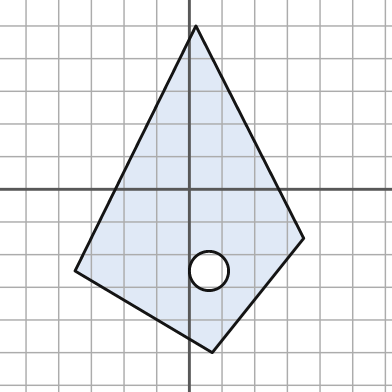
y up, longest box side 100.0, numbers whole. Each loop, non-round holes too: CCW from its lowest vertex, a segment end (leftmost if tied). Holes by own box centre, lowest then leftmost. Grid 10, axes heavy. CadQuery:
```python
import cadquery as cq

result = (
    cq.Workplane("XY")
    .moveTo(7.0, -50.0)
    .lineTo(35.0, -15.0)
    .lineTo(2.0, 50.0)
    .lineTo(-35.0, -25.0)
    .close()
    .moveTo(6.0, -25.0)
    .circle(6.0)
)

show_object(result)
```